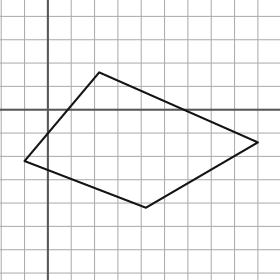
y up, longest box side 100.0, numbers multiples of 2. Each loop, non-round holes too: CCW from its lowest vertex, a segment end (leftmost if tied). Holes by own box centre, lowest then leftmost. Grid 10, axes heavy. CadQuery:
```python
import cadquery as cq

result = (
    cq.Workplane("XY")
    .moveTo(42.0, -42.0)
    .lineTo(90.0, -14.0)
    .lineTo(22.0, 16.0)
    .lineTo(-10.0, -22.0)
    .close()
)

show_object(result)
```